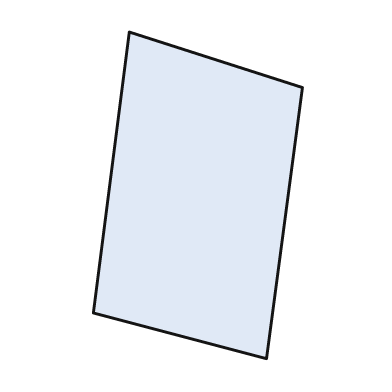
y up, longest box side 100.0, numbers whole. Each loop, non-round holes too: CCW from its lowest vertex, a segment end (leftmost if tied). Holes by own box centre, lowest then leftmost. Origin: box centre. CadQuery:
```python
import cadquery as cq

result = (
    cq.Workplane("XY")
    .moveTo(21.0, -50.0)
    .lineTo(32.0, 33.0)
    .lineTo(-21.0, 50.0)
    .lineTo(-32.0, -36.0)
    .close()
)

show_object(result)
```